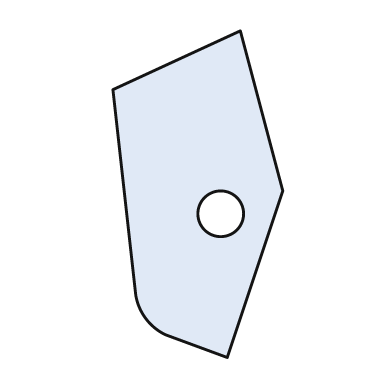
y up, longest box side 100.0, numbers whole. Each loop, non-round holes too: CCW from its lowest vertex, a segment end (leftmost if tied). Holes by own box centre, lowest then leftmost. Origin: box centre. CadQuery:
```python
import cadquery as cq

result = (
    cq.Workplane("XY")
    .moveTo(9.0, -50.0)
    .lineTo(26.0, 1.0)
    .lineTo(13.0, 50.0)
    .lineTo(-26.0, 32.0)
    .lineTo(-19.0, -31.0)
    .threePointArc((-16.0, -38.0), (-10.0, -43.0))
    .close()
    .moveTo(7.0, -6.0)
    .circle(7.0)
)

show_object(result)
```